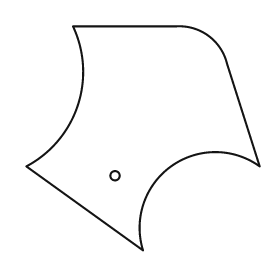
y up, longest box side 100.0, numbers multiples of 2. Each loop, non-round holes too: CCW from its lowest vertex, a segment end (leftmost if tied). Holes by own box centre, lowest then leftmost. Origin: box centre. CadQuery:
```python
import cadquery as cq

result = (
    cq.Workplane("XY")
    .moveTo(0.0, -48.0)
    .threePointArc((12.0, -12.0), (50.0, -12.0))
    .lineTo(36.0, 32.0)
    .threePointArc((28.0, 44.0), (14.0, 48.0))
    .lineTo(-30.0, 48.0)
    .threePointArc((-28.0, 14.0), (-50.0, -12.0))
    .close()
    .moveTo(-12.0, -16.0)
    .circle(2.0)
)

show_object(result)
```